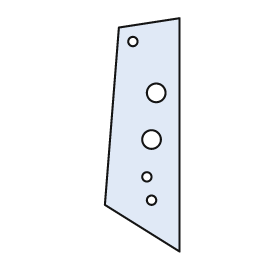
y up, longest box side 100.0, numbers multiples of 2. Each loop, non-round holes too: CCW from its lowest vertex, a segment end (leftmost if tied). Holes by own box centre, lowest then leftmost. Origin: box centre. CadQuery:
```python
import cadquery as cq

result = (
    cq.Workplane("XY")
    .moveTo(16.0, -50.0)
    .lineTo(16.0, 50.0)
    .lineTo(-10.0, 46.0)
    .lineTo(-16.0, -30.0)
    .close()
    .moveTo(4.0, -28.0)
    .circle(2.0)
    .moveTo(2.0, -18.0)
    .circle(2.0)
    .moveTo(4.0, -2.0)
    .circle(4.0)
    .moveTo(6.0, 18.0)
    .circle(4.0)
    .moveTo(-4.0, 40.0)
    .circle(2.0)
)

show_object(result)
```